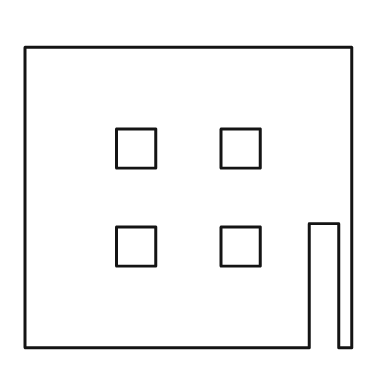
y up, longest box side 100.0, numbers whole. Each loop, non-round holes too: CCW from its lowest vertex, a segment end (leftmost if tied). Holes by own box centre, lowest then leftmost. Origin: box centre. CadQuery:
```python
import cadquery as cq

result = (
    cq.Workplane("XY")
    .moveTo(-50.0, -46.0)
    .lineTo(37.0, -46.0)
    .lineTo(37.0, -8.0)
    .lineTo(46.0, -8.0)
    .lineTo(46.0, -46.0)
    .lineTo(50.0, -46.0)
    .lineTo(50.0, 46.0)
    .lineTo(-50.0, 46.0)
    .close()
    .moveTo(-22.0, -21.0)
    .lineTo(-10.0, -21.0)
    .lineTo(-10.0, -9.0)
    .lineTo(-22.0, -9.0)
    .close()
    .moveTo(10.0, -21.0)
    .lineTo(22.0, -21.0)
    .lineTo(22.0, -9.0)
    .lineTo(10.0, -9.0)
    .close()
    .moveTo(-22.0, 9.0)
    .lineTo(-10.0, 9.0)
    .lineTo(-10.0, 21.0)
    .lineTo(-22.0, 21.0)
    .close()
    .moveTo(10.0, 9.0)
    .lineTo(22.0, 9.0)
    .lineTo(22.0, 21.0)
    .lineTo(10.0, 21.0)
    .close()
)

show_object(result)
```